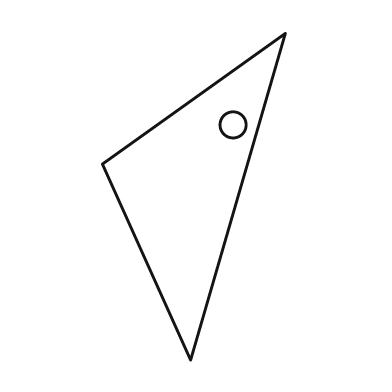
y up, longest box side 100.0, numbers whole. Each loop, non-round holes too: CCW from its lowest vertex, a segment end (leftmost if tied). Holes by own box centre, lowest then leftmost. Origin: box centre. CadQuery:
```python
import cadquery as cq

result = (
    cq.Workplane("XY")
    .moveTo(-1.0, -50.0)
    .lineTo(28.0, 50.0)
    .lineTo(-28.0, 10.0)
    .close()
    .moveTo(12.0, 22.0)
    .circle(4.0)
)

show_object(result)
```